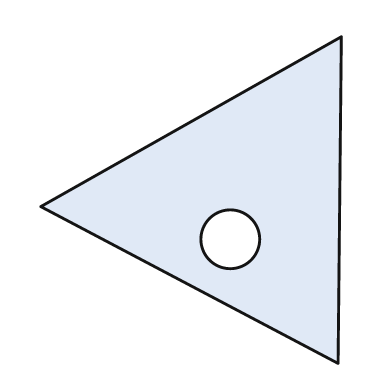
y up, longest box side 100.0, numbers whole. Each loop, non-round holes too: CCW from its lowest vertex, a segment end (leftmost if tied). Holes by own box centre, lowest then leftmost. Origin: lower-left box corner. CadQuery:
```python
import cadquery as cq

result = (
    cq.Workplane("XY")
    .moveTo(91.0, 0.0)
    .lineTo(92.0, 100.0)
    .lineTo(0.0, 48.0)
    .close()
    .moveTo(58.0, 38.0)
    .circle(9.0)
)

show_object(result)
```